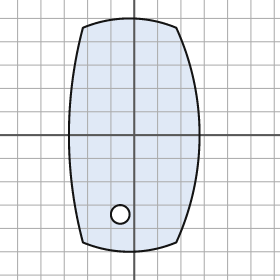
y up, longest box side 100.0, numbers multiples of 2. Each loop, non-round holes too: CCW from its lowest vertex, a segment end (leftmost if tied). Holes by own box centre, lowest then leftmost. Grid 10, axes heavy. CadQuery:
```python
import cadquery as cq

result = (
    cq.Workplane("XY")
    .moveTo(-22.0, -46.0)
    .threePointArc((-2.0, -50.0), (18.0, -46.0))
    .threePointArc((28.0, 0.0), (18.0, 46.0))
    .threePointArc((-2.0, 50.0), (-22.0, 46.0))
    .threePointArc((-28.0, 0.0), (-22.0, -46.0))
    .close()
    .moveTo(-6.0, -34.0)
    .circle(4.0)
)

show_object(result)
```